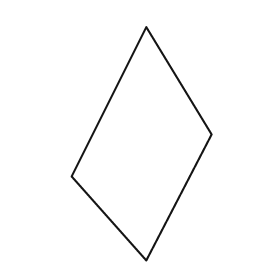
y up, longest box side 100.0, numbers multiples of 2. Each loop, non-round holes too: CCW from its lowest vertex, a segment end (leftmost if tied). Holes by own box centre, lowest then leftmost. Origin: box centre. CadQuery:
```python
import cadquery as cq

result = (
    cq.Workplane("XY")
    .moveTo(2.0, -50.0)
    .lineTo(30.0, 4.0)
    .lineTo(2.0, 50.0)
    .lineTo(-30.0, -14.0)
    .close()
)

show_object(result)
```